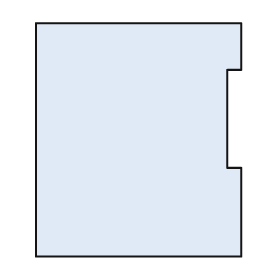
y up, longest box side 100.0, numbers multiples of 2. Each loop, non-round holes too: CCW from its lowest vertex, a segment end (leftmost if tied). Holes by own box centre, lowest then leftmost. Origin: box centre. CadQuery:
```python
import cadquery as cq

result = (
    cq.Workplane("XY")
    .moveTo(-44.0, -50.0)
    .lineTo(44.0, -50.0)
    .lineTo(44.0, -12.0)
    .lineTo(38.0, -12.0)
    .lineTo(38.0, 30.0)
    .lineTo(44.0, 30.0)
    .lineTo(44.0, 50.0)
    .lineTo(-44.0, 50.0)
    .close()
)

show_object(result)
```